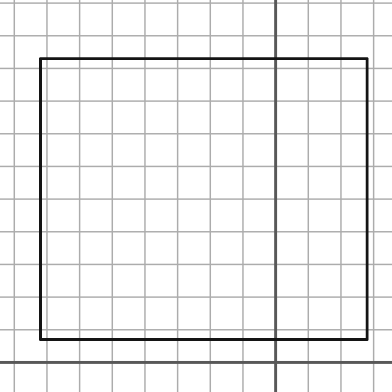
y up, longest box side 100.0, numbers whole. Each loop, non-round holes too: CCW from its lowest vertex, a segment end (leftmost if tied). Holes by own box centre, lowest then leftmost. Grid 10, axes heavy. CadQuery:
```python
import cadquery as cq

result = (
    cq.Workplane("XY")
    .moveTo(-72.0, 7.0)
    .lineTo(28.0, 7.0)
    .lineTo(28.0, 93.0)
    .lineTo(-72.0, 93.0)
    .close()
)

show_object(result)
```